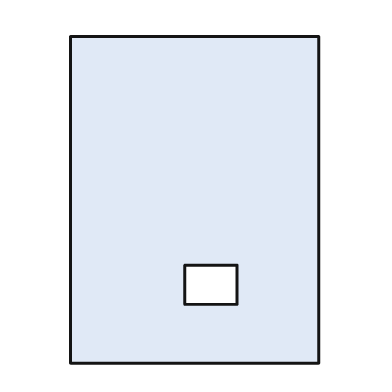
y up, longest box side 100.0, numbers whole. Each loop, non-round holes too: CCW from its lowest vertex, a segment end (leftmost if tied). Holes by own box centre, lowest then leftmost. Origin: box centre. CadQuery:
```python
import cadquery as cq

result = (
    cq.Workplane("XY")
    .moveTo(-38.0, -50.0)
    .lineTo(38.0, -50.0)
    .lineTo(38.0, 50.0)
    .lineTo(-38.0, 50.0)
    .close()
    .moveTo(-3.0, -32.0)
    .lineTo(13.0, -32.0)
    .lineTo(13.0, -20.0)
    .lineTo(-3.0, -20.0)
    .close()
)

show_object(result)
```